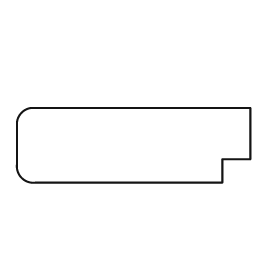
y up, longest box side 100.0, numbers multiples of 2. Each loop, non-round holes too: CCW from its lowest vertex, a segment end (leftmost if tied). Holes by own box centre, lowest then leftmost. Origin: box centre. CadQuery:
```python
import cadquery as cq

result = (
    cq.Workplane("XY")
    .moveTo(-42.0, -16.0)
    .lineTo(38.0, -16.0)
    .lineTo(38.0, -6.0)
    .lineTo(50.0, -6.0)
    .lineTo(50.0, 16.0)
    .lineTo(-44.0, 16.0)
    .threePointArc((-48.0, 14.0), (-50.0, 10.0))
    .lineTo(-50.0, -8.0)
    .threePointArc((-48.0, -14.0), (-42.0, -16.0))
    .close()
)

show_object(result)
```